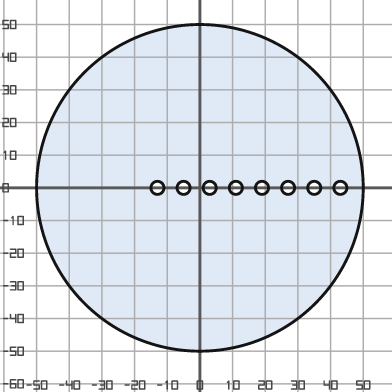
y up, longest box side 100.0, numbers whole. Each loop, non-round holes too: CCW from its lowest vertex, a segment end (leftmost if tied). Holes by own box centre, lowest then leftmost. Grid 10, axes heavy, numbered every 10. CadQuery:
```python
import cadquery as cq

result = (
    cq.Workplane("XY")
    .moveTo(0.0, 0.0)
    .circle(50.0)
    .moveTo(-13.0, 0.0)
    .circle(2.0)
    .moveTo(-5.0, 0.0)
    .circle(2.0)
    .moveTo(3.0, 0.0)
    .circle(2.0)
    .moveTo(11.0, 0.0)
    .circle(2.0)
    .moveTo(19.0, 0.0)
    .circle(2.0)
    .moveTo(27.0, 0.0)
    .circle(2.0)
    .moveTo(35.0, 0.0)
    .circle(2.0)
    .moveTo(43.0, 0.0)
    .circle(2.0)
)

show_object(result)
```